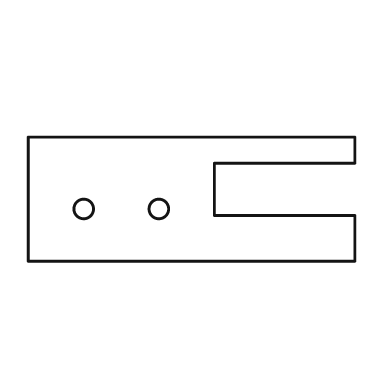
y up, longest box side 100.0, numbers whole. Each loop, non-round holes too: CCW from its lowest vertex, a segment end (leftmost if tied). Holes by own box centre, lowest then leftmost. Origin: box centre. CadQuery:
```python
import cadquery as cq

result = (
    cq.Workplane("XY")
    .moveTo(-50.0, -19.0)
    .lineTo(50.0, -19.0)
    .lineTo(50.0, -5.0)
    .lineTo(7.0, -5.0)
    .lineTo(7.0, 11.0)
    .lineTo(50.0, 11.0)
    .lineTo(50.0, 19.0)
    .lineTo(-50.0, 19.0)
    .close()
    .moveTo(-33.0, -3.0)
    .circle(3.0)
    .moveTo(-10.0, -3.0)
    .circle(3.0)
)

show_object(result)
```